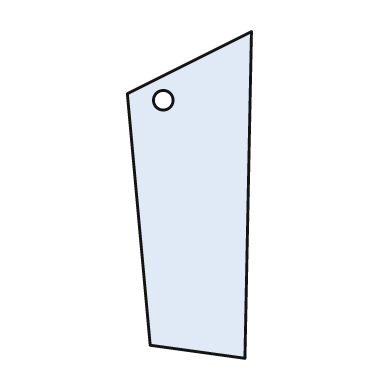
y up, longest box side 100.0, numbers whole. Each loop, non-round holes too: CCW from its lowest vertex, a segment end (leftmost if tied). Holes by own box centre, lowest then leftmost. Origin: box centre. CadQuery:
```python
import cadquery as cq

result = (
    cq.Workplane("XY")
    .moveTo(17.0, -50.0)
    .lineTo(19.0, 50.0)
    .lineTo(-19.0, 31.0)
    .lineTo(-12.0, -46.0)
    .close()
    .moveTo(-8.0, 29.0)
    .circle(3.0)
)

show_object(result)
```